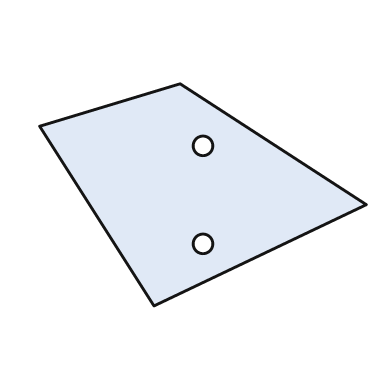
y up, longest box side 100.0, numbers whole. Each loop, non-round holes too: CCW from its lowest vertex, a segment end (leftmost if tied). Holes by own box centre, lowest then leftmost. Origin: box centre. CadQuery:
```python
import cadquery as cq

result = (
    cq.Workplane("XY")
    .moveTo(-15.0, -34.0)
    .lineTo(50.0, -3.0)
    .lineTo(-7.0, 34.0)
    .lineTo(-50.0, 21.0)
    .close()
    .moveTo(0.0, -15.0)
    .circle(3.0)
    .moveTo(0.0, 15.0)
    .circle(3.0)
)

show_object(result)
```